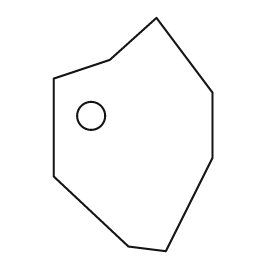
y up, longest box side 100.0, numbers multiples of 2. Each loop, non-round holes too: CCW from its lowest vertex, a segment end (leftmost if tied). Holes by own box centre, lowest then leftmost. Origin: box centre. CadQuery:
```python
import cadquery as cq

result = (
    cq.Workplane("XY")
    .moveTo(14.0, -50.0)
    .lineTo(34.0, -10.0)
    .lineTo(34.0, 18.0)
    .lineTo(10.0, 50.0)
    .lineTo(-10.0, 32.0)
    .lineTo(-34.0, 24.0)
    .lineTo(-34.0, -18.0)
    .lineTo(-2.0, -48.0)
    .close()
    .moveTo(-18.0, 8.0)
    .circle(6.0)
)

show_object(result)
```